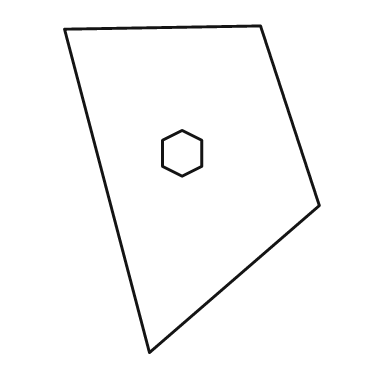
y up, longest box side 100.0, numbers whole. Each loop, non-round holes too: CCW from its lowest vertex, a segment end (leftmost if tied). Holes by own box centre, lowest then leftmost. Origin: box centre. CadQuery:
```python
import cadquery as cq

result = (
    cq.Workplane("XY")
    .moveTo(-13.0, -50.0)
    .lineTo(39.0, -5.0)
    .lineTo(21.0, 50.0)
    .lineTo(-39.0, 49.0)
    .close()
    .moveTo(-3.0, 4.0)
    .lineTo(3.0, 7.0)
    .lineTo(3.0, 15.0)
    .lineTo(-3.0, 18.0)
    .lineTo(-9.0, 15.0)
    .lineTo(-9.0, 7.0)
    .close()
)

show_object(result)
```